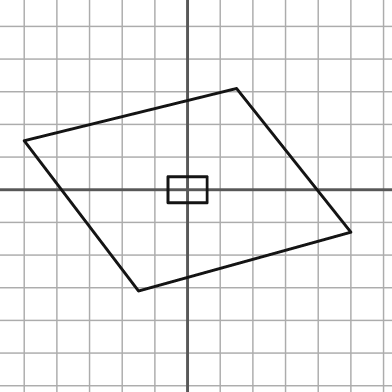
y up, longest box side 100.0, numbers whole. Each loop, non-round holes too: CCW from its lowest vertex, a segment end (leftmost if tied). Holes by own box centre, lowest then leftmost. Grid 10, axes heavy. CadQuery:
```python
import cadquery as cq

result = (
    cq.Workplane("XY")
    .moveTo(-15.0, -31.0)
    .lineTo(50.0, -13.0)
    .lineTo(15.0, 31.0)
    .lineTo(-50.0, 15.0)
    .close()
    .moveTo(-6.0, -4.0)
    .lineTo(6.0, -4.0)
    .lineTo(6.0, 4.0)
    .lineTo(-6.0, 4.0)
    .close()
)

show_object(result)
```